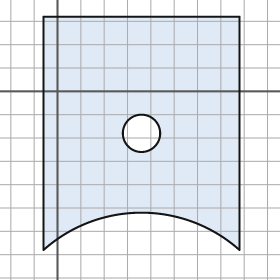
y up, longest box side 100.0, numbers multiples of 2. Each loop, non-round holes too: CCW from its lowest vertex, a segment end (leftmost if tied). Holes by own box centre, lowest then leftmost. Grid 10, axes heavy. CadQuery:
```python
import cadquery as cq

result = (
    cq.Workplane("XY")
    .moveTo(-6.0, -68.0)
    .threePointArc((36.0, -52.0), (78.0, -68.0))
    .lineTo(78.0, 32.0)
    .lineTo(-6.0, 32.0)
    .close()
    .moveTo(36.0, -18.0)
    .circle(8.0)
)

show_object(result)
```